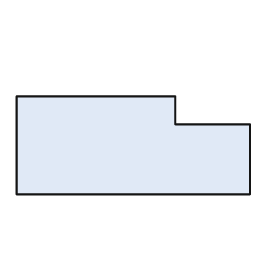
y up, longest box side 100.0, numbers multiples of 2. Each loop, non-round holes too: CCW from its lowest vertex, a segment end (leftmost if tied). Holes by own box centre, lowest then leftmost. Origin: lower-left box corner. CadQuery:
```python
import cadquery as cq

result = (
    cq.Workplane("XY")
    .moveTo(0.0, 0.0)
    .lineTo(100.0, 0.0)
    .lineTo(100.0, 30.0)
    .lineTo(68.0, 30.0)
    .lineTo(68.0, 42.0)
    .lineTo(0.0, 42.0)
    .close()
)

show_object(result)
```